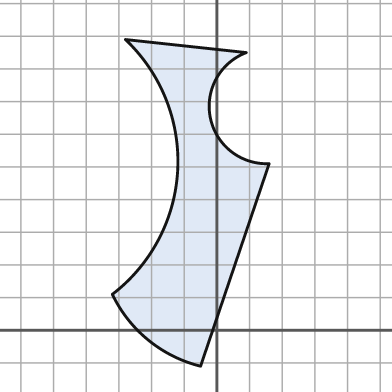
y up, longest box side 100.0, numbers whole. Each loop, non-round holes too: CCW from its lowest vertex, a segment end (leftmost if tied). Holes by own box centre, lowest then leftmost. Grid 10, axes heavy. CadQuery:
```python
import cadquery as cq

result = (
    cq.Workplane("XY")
    .moveTo(-5.0, -11.0)
    .lineTo(16.0, 51.0)
    .threePointArc((-2.0, 65.0), (9.0, 85.0))
    .lineTo(-28.0, 89.0)
    .threePointArc((-12.0, 49.0), (-32.0, 11.0))
    .threePointArc((-21.0, -3.0), (-5.0, -11.0))
    .close()
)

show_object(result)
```